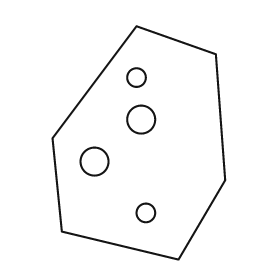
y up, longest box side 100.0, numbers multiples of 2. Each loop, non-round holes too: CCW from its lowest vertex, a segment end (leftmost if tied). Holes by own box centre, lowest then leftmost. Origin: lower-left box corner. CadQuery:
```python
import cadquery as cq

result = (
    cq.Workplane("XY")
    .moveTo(54.0, 0.0)
    .lineTo(74.0, 34.0)
    .lineTo(70.0, 88.0)
    .lineTo(36.0, 100.0)
    .lineTo(0.0, 52.0)
    .lineTo(4.0, 12.0)
    .close()
    .moveTo(40.0, 20.0)
    .circle(4.0)
    .moveTo(18.0, 42.0)
    .circle(6.0)
    .moveTo(38.0, 60.0)
    .circle(6.0)
    .moveTo(36.0, 78.0)
    .circle(4.0)
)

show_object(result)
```